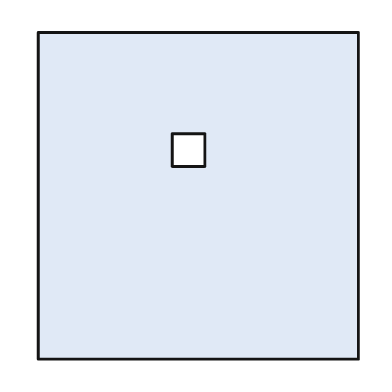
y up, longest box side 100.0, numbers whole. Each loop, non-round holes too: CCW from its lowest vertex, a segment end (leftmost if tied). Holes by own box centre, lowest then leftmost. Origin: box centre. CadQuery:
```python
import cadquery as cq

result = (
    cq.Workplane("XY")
    .moveTo(-49.0, -50.0)
    .lineTo(49.0, -50.0)
    .lineTo(49.0, 50.0)
    .lineTo(-49.0, 50.0)
    .close()
    .moveTo(-8.0, 9.0)
    .lineTo(2.0, 9.0)
    .lineTo(2.0, 19.0)
    .lineTo(-8.0, 19.0)
    .close()
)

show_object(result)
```